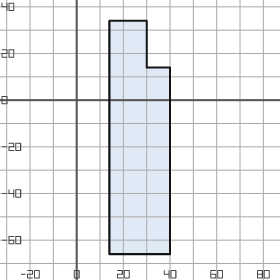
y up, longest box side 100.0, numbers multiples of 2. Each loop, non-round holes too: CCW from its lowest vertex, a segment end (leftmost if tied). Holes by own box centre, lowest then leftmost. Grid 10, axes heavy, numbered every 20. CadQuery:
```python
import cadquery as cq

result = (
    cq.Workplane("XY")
    .moveTo(14.0, -66.0)
    .lineTo(40.0, -66.0)
    .lineTo(40.0, 14.0)
    .lineTo(30.0, 14.0)
    .lineTo(30.0, 34.0)
    .lineTo(14.0, 34.0)
    .close()
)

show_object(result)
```